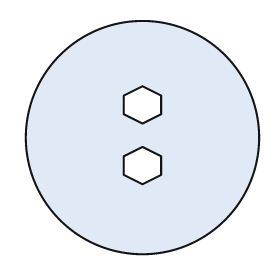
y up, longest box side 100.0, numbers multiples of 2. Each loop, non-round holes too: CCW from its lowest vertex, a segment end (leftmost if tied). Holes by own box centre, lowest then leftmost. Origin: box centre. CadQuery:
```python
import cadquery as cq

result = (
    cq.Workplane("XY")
    .moveTo(0.0, 0.0)
    .circle(50.0)
    .moveTo(0.0, -20.0)
    .lineTo(8.0, -16.0)
    .lineTo(8.0, -8.0)
    .lineTo(0.0, -4.0)
    .lineTo(-8.0, -8.0)
    .lineTo(-8.0, -16.0)
    .close()
    .moveTo(0.0, 6.0)
    .lineTo(8.0, 10.0)
    .lineTo(8.0, 18.0)
    .lineTo(0.0, 22.0)
    .lineTo(-8.0, 18.0)
    .lineTo(-8.0, 10.0)
    .close()
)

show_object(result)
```